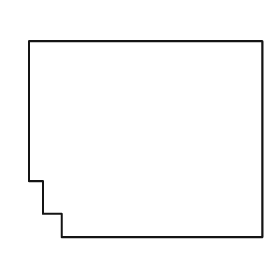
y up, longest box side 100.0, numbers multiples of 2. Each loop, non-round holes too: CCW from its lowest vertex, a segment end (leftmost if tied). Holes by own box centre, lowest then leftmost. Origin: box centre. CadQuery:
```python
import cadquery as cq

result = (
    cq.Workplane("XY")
    .moveTo(-36.0, -42.0)
    .lineTo(50.0, -42.0)
    .lineTo(50.0, 42.0)
    .lineTo(-50.0, 42.0)
    .lineTo(-50.0, -18.0)
    .lineTo(-44.0, -18.0)
    .lineTo(-44.0, -32.0)
    .lineTo(-36.0, -32.0)
    .close()
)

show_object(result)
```